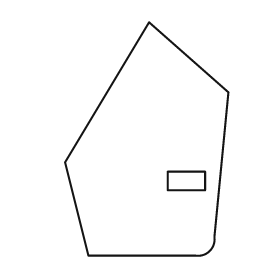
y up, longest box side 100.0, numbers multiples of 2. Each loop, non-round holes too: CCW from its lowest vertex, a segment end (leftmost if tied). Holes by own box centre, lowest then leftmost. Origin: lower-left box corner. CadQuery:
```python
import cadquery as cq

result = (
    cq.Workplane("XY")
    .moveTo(10.0, 0.0)
    .lineTo(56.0, 0.0)
    .threePointArc((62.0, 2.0), (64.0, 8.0))
    .lineTo(70.0, 70.0)
    .lineTo(36.0, 100.0)
    .lineTo(0.0, 40.0)
    .close()
    .moveTo(44.0, 28.0)
    .lineTo(60.0, 28.0)
    .lineTo(60.0, 36.0)
    .lineTo(44.0, 36.0)
    .close()
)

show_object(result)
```